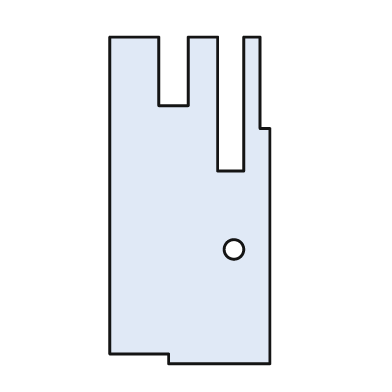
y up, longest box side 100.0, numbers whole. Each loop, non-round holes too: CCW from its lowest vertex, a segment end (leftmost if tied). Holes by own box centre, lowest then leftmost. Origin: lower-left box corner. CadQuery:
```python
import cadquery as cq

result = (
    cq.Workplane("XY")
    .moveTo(18.0, 0.0)
    .lineTo(49.0, 0.0)
    .lineTo(49.0, 72.0)
    .lineTo(46.0, 72.0)
    .lineTo(46.0, 100.0)
    .lineTo(41.0, 100.0)
    .lineTo(41.0, 59.0)
    .lineTo(33.0, 59.0)
    .lineTo(33.0, 100.0)
    .lineTo(24.0, 100.0)
    .lineTo(24.0, 79.0)
    .lineTo(15.0, 79.0)
    .lineTo(15.0, 100.0)
    .lineTo(0.0, 100.0)
    .lineTo(0.0, 3.0)
    .lineTo(18.0, 3.0)
    .close()
    .moveTo(38.0, 35.0)
    .circle(3.0)
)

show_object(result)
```